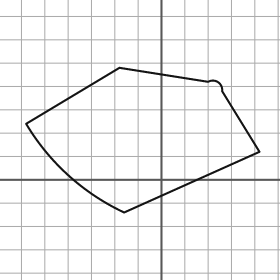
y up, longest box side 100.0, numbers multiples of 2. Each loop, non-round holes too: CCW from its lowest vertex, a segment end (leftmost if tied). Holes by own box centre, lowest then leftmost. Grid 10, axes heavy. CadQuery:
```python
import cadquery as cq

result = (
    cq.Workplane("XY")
    .moveTo(-16.0, -14.0)
    .lineTo(42.0, 12.0)
    .lineTo(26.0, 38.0)
    .threePointArc((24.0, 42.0), (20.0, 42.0))
    .lineTo(-18.0, 48.0)
    .lineTo(-58.0, 24.0)
    .threePointArc((-40.0, 2.0), (-16.0, -14.0))
    .close()
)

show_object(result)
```